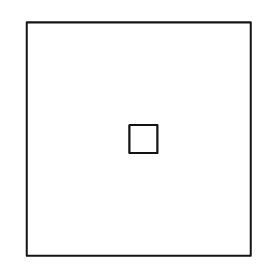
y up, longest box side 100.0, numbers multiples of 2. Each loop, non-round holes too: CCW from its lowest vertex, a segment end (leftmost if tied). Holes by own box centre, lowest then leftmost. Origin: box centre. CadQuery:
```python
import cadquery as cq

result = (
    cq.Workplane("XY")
    .moveTo(-48.0, -50.0)
    .lineTo(48.0, -50.0)
    .lineTo(48.0, 50.0)
    .lineTo(-48.0, 50.0)
    .close()
    .moveTo(-4.0, -6.0)
    .lineTo(8.0, -6.0)
    .lineTo(8.0, 6.0)
    .lineTo(-4.0, 6.0)
    .close()
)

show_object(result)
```